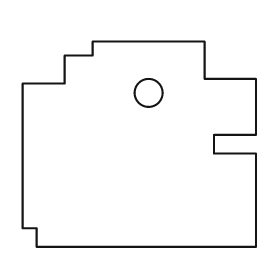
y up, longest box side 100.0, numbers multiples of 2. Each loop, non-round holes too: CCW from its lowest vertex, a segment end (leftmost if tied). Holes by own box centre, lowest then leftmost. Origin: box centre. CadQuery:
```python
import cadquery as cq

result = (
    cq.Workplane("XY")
    .moveTo(-44.0, -44.0)
    .lineTo(50.0, -44.0)
    .lineTo(50.0, -4.0)
    .lineTo(32.0, -4.0)
    .lineTo(32.0, 4.0)
    .lineTo(50.0, 4.0)
    .lineTo(50.0, 28.0)
    .lineTo(28.0, 28.0)
    .lineTo(28.0, 44.0)
    .lineTo(-20.0, 44.0)
    .lineTo(-20.0, 38.0)
    .lineTo(-32.0, 38.0)
    .lineTo(-32.0, 26.0)
    .lineTo(-50.0, 26.0)
    .lineTo(-50.0, -36.0)
    .lineTo(-44.0, -36.0)
    .close()
    .moveTo(4.0, 22.0)
    .circle(6.0)
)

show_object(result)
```